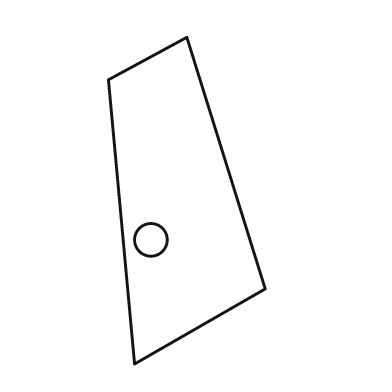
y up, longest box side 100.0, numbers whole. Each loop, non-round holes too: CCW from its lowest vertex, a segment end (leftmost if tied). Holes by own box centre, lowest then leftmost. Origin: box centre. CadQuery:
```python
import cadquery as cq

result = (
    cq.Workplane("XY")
    .moveTo(-16.0, -50.0)
    .lineTo(24.0, -27.0)
    .lineTo(0.0, 50.0)
    .lineTo(-24.0, 37.0)
    .close()
    .moveTo(-11.0, -12.0)
    .circle(5.0)
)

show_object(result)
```